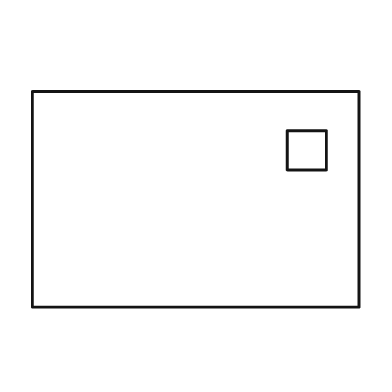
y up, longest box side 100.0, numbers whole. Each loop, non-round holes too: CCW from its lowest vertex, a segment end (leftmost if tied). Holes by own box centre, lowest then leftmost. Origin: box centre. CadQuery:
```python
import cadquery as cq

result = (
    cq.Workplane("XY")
    .moveTo(-50.0, -33.0)
    .lineTo(50.0, -33.0)
    .lineTo(50.0, 33.0)
    .lineTo(-50.0, 33.0)
    .close()
    .moveTo(28.0, 9.0)
    .lineTo(40.0, 9.0)
    .lineTo(40.0, 21.0)
    .lineTo(28.0, 21.0)
    .close()
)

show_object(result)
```